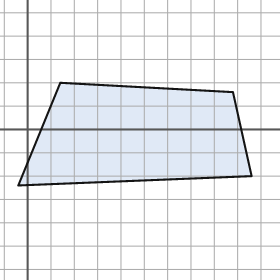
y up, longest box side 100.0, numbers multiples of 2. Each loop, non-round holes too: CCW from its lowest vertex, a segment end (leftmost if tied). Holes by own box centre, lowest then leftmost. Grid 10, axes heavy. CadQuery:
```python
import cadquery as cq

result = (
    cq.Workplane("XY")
    .moveTo(-4.0, -24.0)
    .lineTo(96.0, -20.0)
    .lineTo(88.0, 16.0)
    .lineTo(14.0, 20.0)
    .close()
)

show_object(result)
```